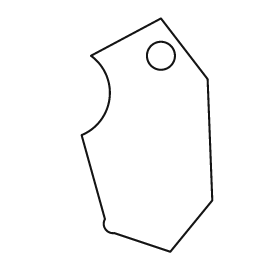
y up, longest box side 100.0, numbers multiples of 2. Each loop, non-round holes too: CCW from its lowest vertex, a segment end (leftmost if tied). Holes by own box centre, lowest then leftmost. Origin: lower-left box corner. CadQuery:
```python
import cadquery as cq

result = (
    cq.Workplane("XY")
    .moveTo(38.0, 0.0)
    .lineTo(56.0, 22.0)
    .lineTo(54.0, 74.0)
    .lineTo(34.0, 100.0)
    .lineTo(4.0, 84.0)
    .threePointArc((12.0, 66.0), (0.0, 50.0))
    .lineTo(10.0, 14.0)
    .threePointArc((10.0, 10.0), (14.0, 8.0))
    .close()
    .moveTo(34.0, 84.0)
    .circle(6.0)
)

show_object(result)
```